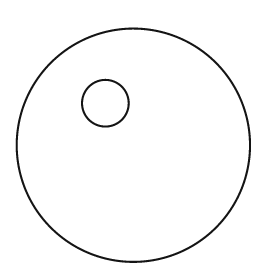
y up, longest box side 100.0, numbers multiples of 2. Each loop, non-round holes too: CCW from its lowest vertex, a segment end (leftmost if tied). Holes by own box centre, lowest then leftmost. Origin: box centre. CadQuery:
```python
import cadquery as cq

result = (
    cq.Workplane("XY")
    .moveTo(0.0, 0.0)
    .circle(50.0)
    .moveTo(-12.0, 18.0)
    .circle(10.0)
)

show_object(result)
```